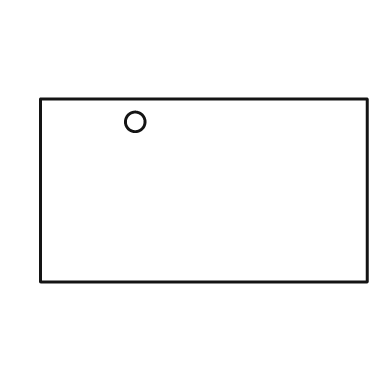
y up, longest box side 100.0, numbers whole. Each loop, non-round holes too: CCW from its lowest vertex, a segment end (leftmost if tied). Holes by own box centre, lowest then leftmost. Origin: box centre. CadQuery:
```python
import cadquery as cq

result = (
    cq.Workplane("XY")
    .moveTo(-50.0, -28.0)
    .lineTo(50.0, -28.0)
    .lineTo(50.0, 28.0)
    .lineTo(-50.0, 28.0)
    .close()
    .moveTo(-21.0, 21.0)
    .circle(3.0)
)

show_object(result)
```